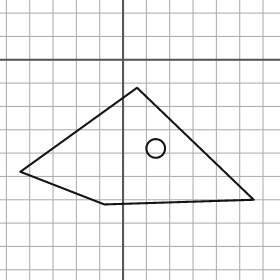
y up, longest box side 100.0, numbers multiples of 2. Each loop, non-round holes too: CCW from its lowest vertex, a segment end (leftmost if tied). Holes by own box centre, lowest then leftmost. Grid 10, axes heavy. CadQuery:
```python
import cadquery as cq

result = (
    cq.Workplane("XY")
    .moveTo(-8.0, -62.0)
    .lineTo(56.0, -60.0)
    .lineTo(6.0, -12.0)
    .lineTo(-44.0, -48.0)
    .close()
    .moveTo(14.0, -38.0)
    .circle(4.0)
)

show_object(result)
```